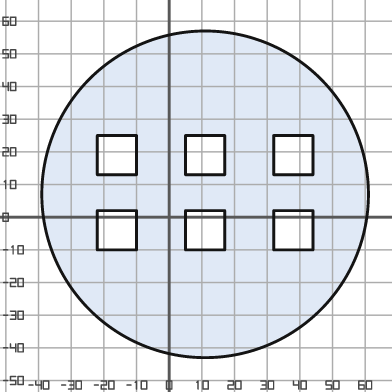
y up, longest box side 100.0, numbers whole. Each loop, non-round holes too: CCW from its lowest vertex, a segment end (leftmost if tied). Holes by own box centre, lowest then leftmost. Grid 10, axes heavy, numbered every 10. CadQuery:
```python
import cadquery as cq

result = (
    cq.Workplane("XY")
    .moveTo(11.0, 7.0)
    .circle(50.0)
    .moveTo(-22.0, -10.0)
    .lineTo(-10.0, -10.0)
    .lineTo(-10.0, 2.0)
    .lineTo(-22.0, 2.0)
    .close()
    .moveTo(5.0, -10.0)
    .lineTo(17.0, -10.0)
    .lineTo(17.0, 2.0)
    .lineTo(5.0, 2.0)
    .close()
    .moveTo(32.0, -10.0)
    .lineTo(44.0, -10.0)
    .lineTo(44.0, 2.0)
    .lineTo(32.0, 2.0)
    .close()
    .moveTo(-22.0, 13.0)
    .lineTo(-10.0, 13.0)
    .lineTo(-10.0, 25.0)
    .lineTo(-22.0, 25.0)
    .close()
    .moveTo(5.0, 13.0)
    .lineTo(17.0, 13.0)
    .lineTo(17.0, 25.0)
    .lineTo(5.0, 25.0)
    .close()
    .moveTo(32.0, 13.0)
    .lineTo(44.0, 13.0)
    .lineTo(44.0, 25.0)
    .lineTo(32.0, 25.0)
    .close()
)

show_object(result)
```